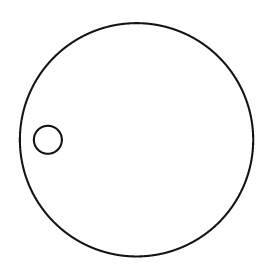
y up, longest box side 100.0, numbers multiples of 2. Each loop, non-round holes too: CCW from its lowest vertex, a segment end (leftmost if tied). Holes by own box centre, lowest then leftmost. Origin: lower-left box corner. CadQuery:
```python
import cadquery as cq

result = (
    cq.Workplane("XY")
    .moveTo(50.0, 50.0)
    .circle(50.0)
    .moveTo(12.0, 50.0)
    .circle(6.0)
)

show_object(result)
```